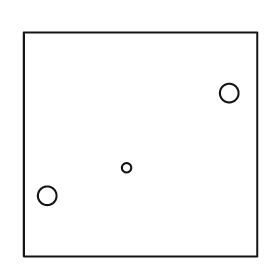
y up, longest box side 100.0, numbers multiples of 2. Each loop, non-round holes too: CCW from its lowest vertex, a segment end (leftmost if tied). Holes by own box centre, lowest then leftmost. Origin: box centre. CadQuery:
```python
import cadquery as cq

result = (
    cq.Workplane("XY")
    .moveTo(-50.0, -48.0)
    .lineTo(50.0, -48.0)
    .lineTo(50.0, 48.0)
    .lineTo(-50.0, 48.0)
    .close()
    .moveTo(-40.0, -22.0)
    .circle(4.0)
    .moveTo(-6.0, -10.0)
    .circle(2.0)
    .moveTo(38.0, 22.0)
    .circle(4.0)
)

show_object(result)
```